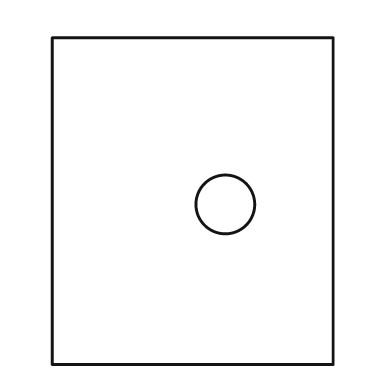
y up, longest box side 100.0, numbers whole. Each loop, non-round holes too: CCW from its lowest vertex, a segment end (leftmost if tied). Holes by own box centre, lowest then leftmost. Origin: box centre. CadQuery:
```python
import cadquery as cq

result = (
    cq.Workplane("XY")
    .moveTo(-43.0, -50.0)
    .lineTo(43.0, -50.0)
    .lineTo(43.0, 50.0)
    .lineTo(-43.0, 50.0)
    .close()
    .moveTo(10.0, -1.0)
    .circle(9.0)
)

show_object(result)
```